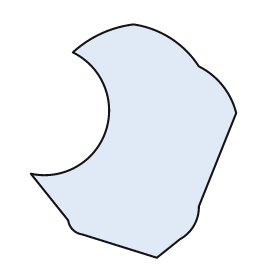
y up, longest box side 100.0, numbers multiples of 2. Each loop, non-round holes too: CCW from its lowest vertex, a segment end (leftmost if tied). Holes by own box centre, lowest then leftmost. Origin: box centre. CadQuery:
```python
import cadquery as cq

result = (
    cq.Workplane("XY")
    .moveTo(10.0, -50.0)
    .lineTo(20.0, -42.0)
    .threePointArc((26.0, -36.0), (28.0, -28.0))
    .lineTo(44.0, 12.0)
    .threePointArc((38.0, 24.0), (28.0, 32.0))
    .threePointArc((16.0, 44.0), (0.0, 50.0))
    .threePointArc((-14.0, 46.0), (-26.0, 38.0))
    .threePointArc((-12.0, 4.0), (-44.0, -14.0))
    .lineTo(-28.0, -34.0)
    .threePointArc((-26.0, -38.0), (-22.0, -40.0))
    .close()
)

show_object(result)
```